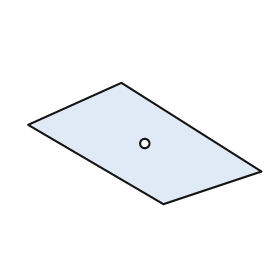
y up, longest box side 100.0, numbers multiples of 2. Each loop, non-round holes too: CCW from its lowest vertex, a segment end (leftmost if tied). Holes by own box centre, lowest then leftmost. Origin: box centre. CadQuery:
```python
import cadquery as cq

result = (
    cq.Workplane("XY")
    .moveTo(8.0, -26.0)
    .lineTo(50.0, -12.0)
    .lineTo(-10.0, 26.0)
    .lineTo(-50.0, 8.0)
    .close()
    .moveTo(0.0, 0.0)
    .circle(2.0)
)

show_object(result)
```